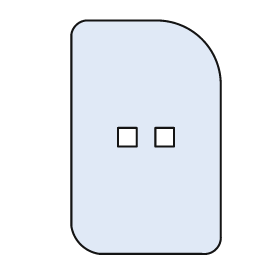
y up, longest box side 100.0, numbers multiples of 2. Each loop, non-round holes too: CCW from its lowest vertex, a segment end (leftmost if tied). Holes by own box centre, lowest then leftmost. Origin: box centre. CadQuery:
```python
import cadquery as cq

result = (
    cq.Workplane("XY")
    .moveTo(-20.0, -50.0)
    .lineTo(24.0, -50.0)
    .threePointArc((30.0, -48.0), (32.0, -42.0))
    .lineTo(32.0, 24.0)
    .threePointArc((24.0, 42.0), (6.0, 50.0))
    .lineTo(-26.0, 50.0)
    .threePointArc((-30.0, 48.0), (-32.0, 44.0))
    .lineTo(-32.0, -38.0)
    .threePointArc((-28.0, -46.0), (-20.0, -50.0))
    .close()
    .moveTo(-12.0, -4.0)
    .lineTo(-4.0, -4.0)
    .lineTo(-4.0, 4.0)
    .lineTo(-12.0, 4.0)
    .close()
    .moveTo(4.0, -4.0)
    .lineTo(12.0, -4.0)
    .lineTo(12.0, 4.0)
    .lineTo(4.0, 4.0)
    .close()
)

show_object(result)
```